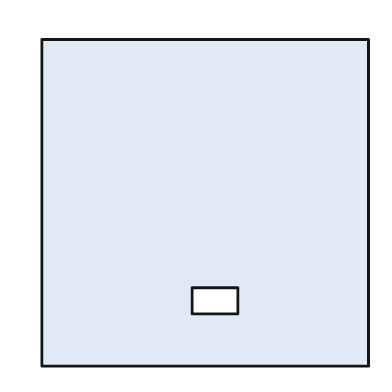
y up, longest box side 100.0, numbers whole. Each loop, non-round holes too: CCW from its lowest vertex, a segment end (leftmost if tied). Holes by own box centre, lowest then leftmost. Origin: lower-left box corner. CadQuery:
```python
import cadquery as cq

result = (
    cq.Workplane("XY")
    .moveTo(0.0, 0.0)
    .lineTo(100.0, 0.0)
    .lineTo(100.0, 100.0)
    .lineTo(0.0, 100.0)
    .close()
    .moveTo(46.0, 16.0)
    .lineTo(60.0, 16.0)
    .lineTo(60.0, 24.0)
    .lineTo(46.0, 24.0)
    .close()
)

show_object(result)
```